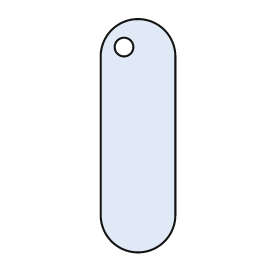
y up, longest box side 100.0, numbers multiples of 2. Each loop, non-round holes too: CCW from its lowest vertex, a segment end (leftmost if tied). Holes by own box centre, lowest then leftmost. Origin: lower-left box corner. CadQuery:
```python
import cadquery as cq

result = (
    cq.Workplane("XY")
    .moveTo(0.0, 16.0)
    .threePointArc((16.0, 0.0), (32.0, 16.0))
    .lineTo(32.0, 84.0)
    .threePointArc((16.0, 100.0), (0.0, 84.0))
    .close()
    .moveTo(10.0, 88.0)
    .circle(4.0)
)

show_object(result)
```